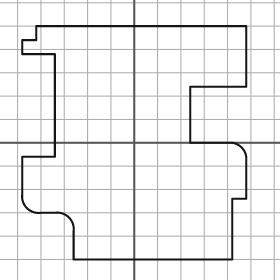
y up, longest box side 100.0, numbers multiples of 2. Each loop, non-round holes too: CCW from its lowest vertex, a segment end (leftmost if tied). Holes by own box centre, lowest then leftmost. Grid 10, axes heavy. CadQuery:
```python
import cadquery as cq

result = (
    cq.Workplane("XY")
    .moveTo(-26.0, -50.0)
    .lineTo(42.0, -50.0)
    .lineTo(42.0, -24.0)
    .lineTo(48.0, -24.0)
    .lineTo(48.0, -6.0)
    .threePointArc((46.0, -2.0), (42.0, 0.0))
    .lineTo(24.0, 0.0)
    .lineTo(24.0, 24.0)
    .lineTo(48.0, 24.0)
    .lineTo(48.0, 50.0)
    .lineTo(-42.0, 50.0)
    .lineTo(-42.0, 44.0)
    .lineTo(-48.0, 44.0)
    .lineTo(-48.0, 38.0)
    .lineTo(-34.0, 38.0)
    .lineTo(-34.0, -6.0)
    .lineTo(-48.0, -6.0)
    .lineTo(-48.0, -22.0)
    .threePointArc((-46.0, -28.0), (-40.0, -30.0))
    .lineTo(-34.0, -30.0)
    .threePointArc((-28.0, -32.0), (-26.0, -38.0))
    .close()
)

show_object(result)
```